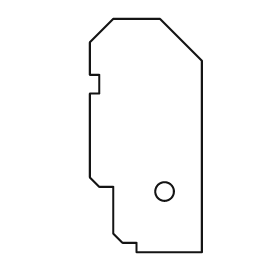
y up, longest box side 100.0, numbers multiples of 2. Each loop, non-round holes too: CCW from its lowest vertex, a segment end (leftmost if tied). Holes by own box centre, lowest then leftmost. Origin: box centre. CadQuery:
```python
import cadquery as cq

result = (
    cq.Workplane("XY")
    .moveTo(-4.0, -50.0)
    .lineTo(24.0, -50.0)
    .lineTo(24.0, 32.0)
    .lineTo(6.0, 50.0)
    .lineTo(-14.0, 50.0)
    .lineTo(-24.0, 40.0)
    .lineTo(-24.0, 26.0)
    .lineTo(-20.0, 26.0)
    .lineTo(-20.0, 18.0)
    .lineTo(-24.0, 18.0)
    .lineTo(-24.0, -18.0)
    .lineTo(-20.0, -22.0)
    .lineTo(-14.0, -22.0)
    .lineTo(-14.0, -42.0)
    .lineTo(-10.0, -46.0)
    .lineTo(-4.0, -46.0)
    .close()
    .moveTo(8.0, -24.0)
    .circle(4.0)
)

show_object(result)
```